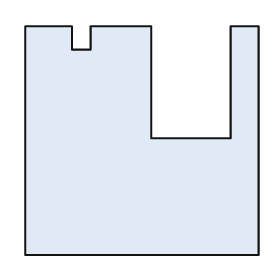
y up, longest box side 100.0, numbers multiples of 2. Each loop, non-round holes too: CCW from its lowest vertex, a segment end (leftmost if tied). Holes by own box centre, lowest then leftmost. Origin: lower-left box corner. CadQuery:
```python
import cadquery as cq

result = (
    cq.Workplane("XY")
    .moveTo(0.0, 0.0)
    .lineTo(100.0, 0.0)
    .lineTo(100.0, 98.0)
    .lineTo(88.0, 98.0)
    .lineTo(88.0, 50.0)
    .lineTo(54.0, 50.0)
    .lineTo(54.0, 98.0)
    .lineTo(28.0, 98.0)
    .lineTo(28.0, 88.0)
    .lineTo(20.0, 88.0)
    .lineTo(20.0, 98.0)
    .lineTo(0.0, 98.0)
    .close()
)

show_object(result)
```